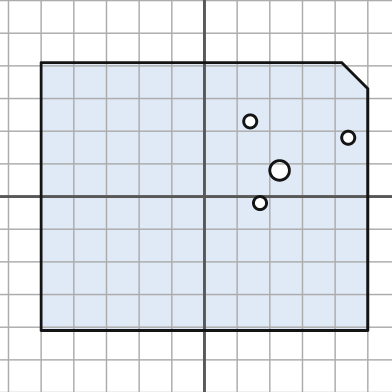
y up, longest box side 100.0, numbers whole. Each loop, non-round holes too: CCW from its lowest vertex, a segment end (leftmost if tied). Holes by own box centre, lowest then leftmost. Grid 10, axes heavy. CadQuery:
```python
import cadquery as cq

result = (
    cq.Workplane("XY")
    .moveTo(-50.0, -41.0)
    .lineTo(50.0, -41.0)
    .lineTo(50.0, 33.0)
    .lineTo(42.0, 41.0)
    .lineTo(-50.0, 41.0)
    .close()
    .moveTo(17.0, -2.0)
    .circle(2.0)
    .moveTo(23.0, 8.0)
    .circle(3.0)
    .moveTo(44.0, 18.0)
    .circle(2.0)
    .moveTo(14.0, 23.0)
    .circle(2.0)
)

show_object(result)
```